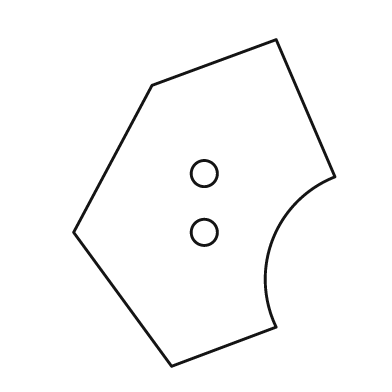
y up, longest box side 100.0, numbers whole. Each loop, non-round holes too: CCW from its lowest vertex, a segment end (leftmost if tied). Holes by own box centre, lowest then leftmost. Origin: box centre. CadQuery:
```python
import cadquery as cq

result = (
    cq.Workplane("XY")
    .moveTo(-10.0, -50.0)
    .lineTo(22.0, -38.0)
    .threePointArc((21.0, -11.0), (40.0, 8.0))
    .lineTo(22.0, 50.0)
    .lineTo(-16.0, 36.0)
    .lineTo(-40.0, -9.0)
    .close()
    .moveTo(0.0, -9.0)
    .circle(4.0)
    .moveTo(0.0, 9.0)
    .circle(4.0)
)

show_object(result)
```